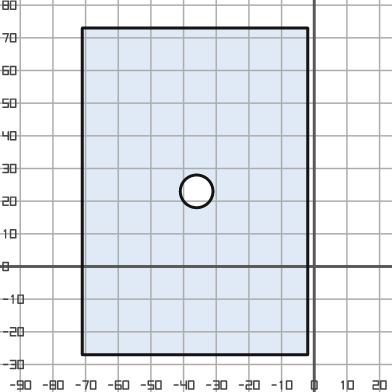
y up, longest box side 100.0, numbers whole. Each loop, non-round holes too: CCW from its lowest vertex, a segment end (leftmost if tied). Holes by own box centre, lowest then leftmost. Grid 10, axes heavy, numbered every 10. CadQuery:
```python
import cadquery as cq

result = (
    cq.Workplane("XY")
    .moveTo(-71.0, -27.0)
    .lineTo(-2.0, -27.0)
    .lineTo(-2.0, 73.0)
    .lineTo(-71.0, 73.0)
    .close()
    .moveTo(-36.0, 23.0)
    .circle(5.0)
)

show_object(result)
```